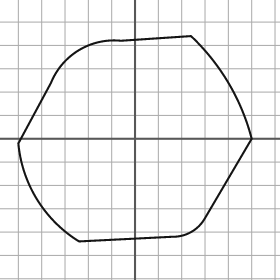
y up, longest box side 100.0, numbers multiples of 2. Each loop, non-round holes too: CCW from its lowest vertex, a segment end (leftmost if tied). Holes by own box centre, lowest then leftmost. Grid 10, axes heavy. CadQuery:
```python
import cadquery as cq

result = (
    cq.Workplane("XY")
    .moveTo(-24.0, -44.0)
    .lineTo(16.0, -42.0)
    .threePointArc((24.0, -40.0), (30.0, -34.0))
    .lineTo(50.0, 0.0)
    .threePointArc((40.0, 24.0), (24.0, 44.0))
    .lineTo(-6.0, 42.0)
    .threePointArc((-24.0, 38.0), (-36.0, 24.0))
    .lineTo(-50.0, -2.0)
    .threePointArc((-42.0, -26.0), (-24.0, -44.0))
    .close()
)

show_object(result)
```